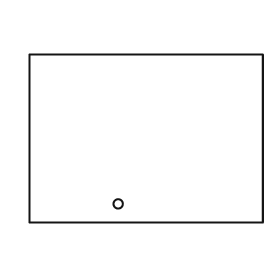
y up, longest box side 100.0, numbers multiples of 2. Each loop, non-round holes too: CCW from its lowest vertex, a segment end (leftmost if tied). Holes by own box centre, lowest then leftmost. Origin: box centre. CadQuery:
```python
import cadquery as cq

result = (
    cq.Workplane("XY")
    .moveTo(-50.0, -36.0)
    .lineTo(50.0, -36.0)
    .lineTo(50.0, 36.0)
    .lineTo(-50.0, 36.0)
    .close()
    .moveTo(-12.0, -28.0)
    .circle(2.0)
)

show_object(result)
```